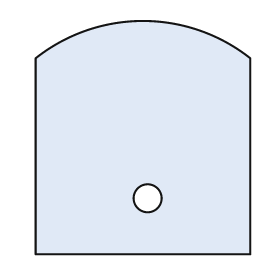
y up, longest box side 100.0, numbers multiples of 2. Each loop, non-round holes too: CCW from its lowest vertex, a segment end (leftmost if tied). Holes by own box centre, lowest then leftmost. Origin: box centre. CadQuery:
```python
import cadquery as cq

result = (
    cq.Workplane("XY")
    .moveTo(-46.0, -50.0)
    .lineTo(46.0, -50.0)
    .lineTo(46.0, 34.0)
    .threePointArc((0.0, 50.0), (-46.0, 34.0))
    .close()
    .moveTo(2.0, -26.0)
    .circle(6.0)
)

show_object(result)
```